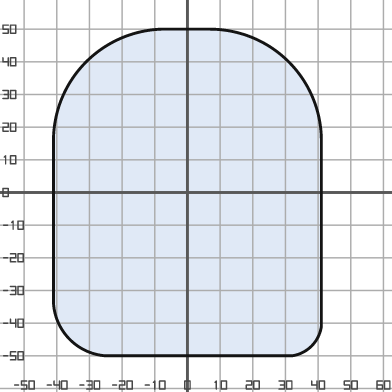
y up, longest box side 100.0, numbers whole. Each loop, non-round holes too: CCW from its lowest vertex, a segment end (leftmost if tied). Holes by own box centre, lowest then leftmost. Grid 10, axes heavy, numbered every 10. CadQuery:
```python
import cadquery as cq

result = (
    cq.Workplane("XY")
    .moveTo(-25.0, -50.0)
    .lineTo(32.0, -50.0)
    .threePointArc((38.0, -47.0), (41.0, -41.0))
    .lineTo(41.0, 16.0)
    .threePointArc((31.0, 40.0), (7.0, 50.0))
    .lineTo(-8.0, 50.0)
    .threePointArc((-31.0, 40.0), (-41.0, 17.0))
    .lineTo(-41.0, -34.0)
    .threePointArc((-36.0, -45.0), (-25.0, -50.0))
    .close()
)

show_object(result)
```